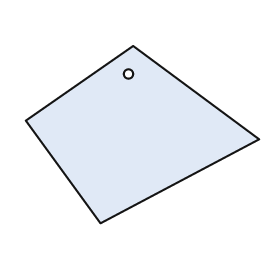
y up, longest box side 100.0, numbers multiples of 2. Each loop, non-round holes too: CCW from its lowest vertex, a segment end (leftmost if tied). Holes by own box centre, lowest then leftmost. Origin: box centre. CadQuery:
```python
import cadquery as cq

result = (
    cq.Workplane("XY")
    .moveTo(-18.0, -38.0)
    .lineTo(50.0, -2.0)
    .lineTo(-4.0, 38.0)
    .lineTo(-50.0, 6.0)
    .close()
    .moveTo(-6.0, 26.0)
    .circle(2.0)
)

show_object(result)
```